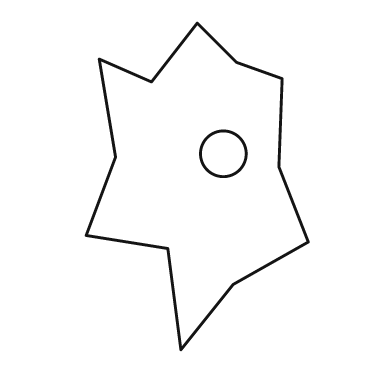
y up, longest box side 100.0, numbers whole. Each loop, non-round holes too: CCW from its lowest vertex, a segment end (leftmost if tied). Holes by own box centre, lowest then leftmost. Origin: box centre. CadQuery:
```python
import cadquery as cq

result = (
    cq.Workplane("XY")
    .moveTo(-5.0, -50.0)
    .lineTo(11.0, -30.0)
    .lineTo(34.0, -17.0)
    .lineTo(25.0, 6.0)
    .lineTo(26.0, 33.0)
    .lineTo(12.0, 38.0)
    .lineTo(0.0, 50.0)
    .lineTo(-14.0, 32.0)
    .lineTo(-30.0, 39.0)
    .lineTo(-25.0, 9.0)
    .lineTo(-34.0, -15.0)
    .lineTo(-9.0, -19.0)
    .close()
    .moveTo(8.0, 10.0)
    .circle(7.0)
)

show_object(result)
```